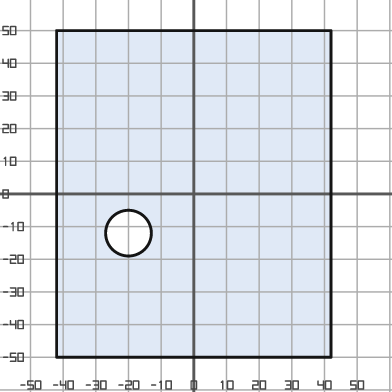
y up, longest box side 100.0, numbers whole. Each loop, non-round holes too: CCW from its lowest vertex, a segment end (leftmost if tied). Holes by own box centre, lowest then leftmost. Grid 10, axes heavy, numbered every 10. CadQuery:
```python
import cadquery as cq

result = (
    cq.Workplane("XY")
    .moveTo(-42.0, -50.0)
    .lineTo(42.0, -50.0)
    .lineTo(42.0, 50.0)
    .lineTo(-42.0, 50.0)
    .close()
    .moveTo(-20.0, -12.0)
    .circle(7.0)
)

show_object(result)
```